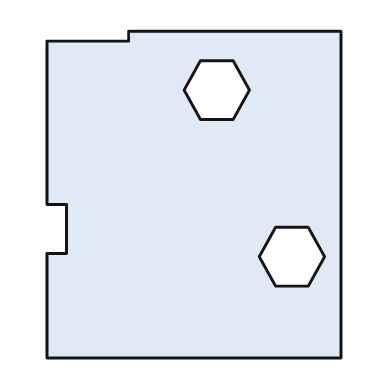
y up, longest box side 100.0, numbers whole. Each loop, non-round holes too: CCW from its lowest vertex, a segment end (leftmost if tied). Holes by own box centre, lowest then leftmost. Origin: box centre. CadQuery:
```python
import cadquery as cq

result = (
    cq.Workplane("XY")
    .moveTo(-45.0, -50.0)
    .lineTo(45.0, -50.0)
    .lineTo(45.0, 50.0)
    .lineTo(-20.0, 50.0)
    .lineTo(-20.0, 47.0)
    .lineTo(-45.0, 47.0)
    .lineTo(-45.0, -3.0)
    .lineTo(-39.0, -3.0)
    .lineTo(-39.0, -18.0)
    .lineTo(-45.0, -18.0)
    .close()
    .moveTo(25.0, -28.0)
    .lineTo(35.0, -28.0)
    .lineTo(40.0, -19.0)
    .lineTo(35.0, -10.0)
    .lineTo(25.0, -10.0)
    .lineTo(20.0, -19.0)
    .close()
    .moveTo(2.0, 23.0)
    .lineTo(12.0, 23.0)
    .lineTo(17.0, 32.0)
    .lineTo(12.0, 41.0)
    .lineTo(2.0, 41.0)
    .lineTo(-3.0, 32.0)
    .close()
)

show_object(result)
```